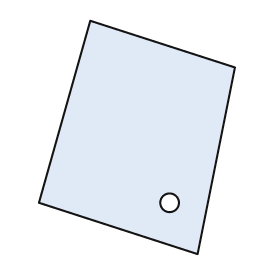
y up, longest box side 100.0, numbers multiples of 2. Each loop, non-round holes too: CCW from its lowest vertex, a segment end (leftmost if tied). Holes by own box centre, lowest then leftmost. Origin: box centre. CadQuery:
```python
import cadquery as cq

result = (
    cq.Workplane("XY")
    .moveTo(26.0, -50.0)
    .lineTo(42.0, 30.0)
    .lineTo(-20.0, 50.0)
    .lineTo(-42.0, -28.0)
    .close()
    .moveTo(14.0, -28.0)
    .circle(4.0)
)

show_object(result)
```